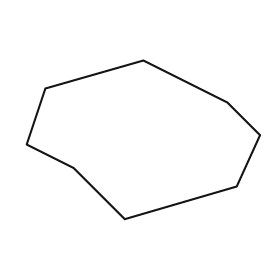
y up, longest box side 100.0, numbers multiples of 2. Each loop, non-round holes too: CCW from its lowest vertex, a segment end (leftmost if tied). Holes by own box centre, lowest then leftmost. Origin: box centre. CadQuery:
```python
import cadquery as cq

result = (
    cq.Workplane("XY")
    .moveTo(-8.0, -34.0)
    .lineTo(40.0, -20.0)
    .lineTo(50.0, 2.0)
    .lineTo(36.0, 16.0)
    .lineTo(0.0, 34.0)
    .lineTo(-42.0, 22.0)
    .lineTo(-50.0, -2.0)
    .lineTo(-30.0, -12.0)
    .close()
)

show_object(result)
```